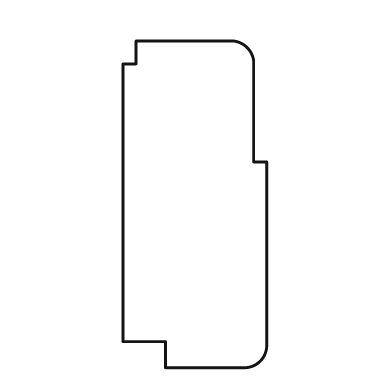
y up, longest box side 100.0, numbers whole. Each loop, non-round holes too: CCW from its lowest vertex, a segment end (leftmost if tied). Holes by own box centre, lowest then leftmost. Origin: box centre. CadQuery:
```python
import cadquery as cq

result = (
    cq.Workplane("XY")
    .moveTo(-9.0, -50.0)
    .lineTo(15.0, -50.0)
    .threePointArc((20.0, -48.0), (22.0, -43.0))
    .lineTo(22.0, 13.0)
    .lineTo(18.0, 13.0)
    .lineTo(18.0, 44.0)
    .threePointArc((16.0, 48.0), (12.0, 50.0))
    .lineTo(-18.0, 50.0)
    .lineTo(-18.0, 43.0)
    .lineTo(-22.0, 43.0)
    .lineTo(-22.0, -42.0)
    .lineTo(-9.0, -42.0)
    .close()
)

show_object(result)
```